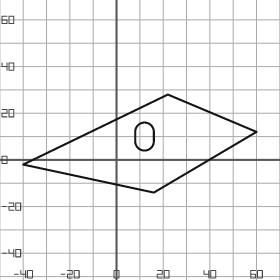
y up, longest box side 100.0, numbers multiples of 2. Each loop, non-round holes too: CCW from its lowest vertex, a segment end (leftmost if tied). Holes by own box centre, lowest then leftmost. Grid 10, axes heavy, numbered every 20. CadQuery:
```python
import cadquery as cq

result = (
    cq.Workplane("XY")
    .moveTo(16.0, -14.0)
    .lineTo(60.0, 12.0)
    .lineTo(22.0, 28.0)
    .lineTo(-40.0, -2.0)
    .close()
    .moveTo(8.0, 8.0)
    .threePointArc((12.0, 4.0), (16.0, 8.0))
    .lineTo(16.0, 12.0)
    .threePointArc((12.0, 16.0), (8.0, 12.0))
    .close()
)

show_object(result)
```